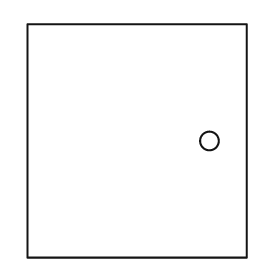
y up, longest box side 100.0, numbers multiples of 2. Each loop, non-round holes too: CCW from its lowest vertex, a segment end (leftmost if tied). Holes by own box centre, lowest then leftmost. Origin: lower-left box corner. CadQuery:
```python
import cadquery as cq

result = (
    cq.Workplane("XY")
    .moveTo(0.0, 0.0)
    .lineTo(94.0, 0.0)
    .lineTo(94.0, 100.0)
    .lineTo(0.0, 100.0)
    .close()
    .moveTo(78.0, 50.0)
    .circle(4.0)
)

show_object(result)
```